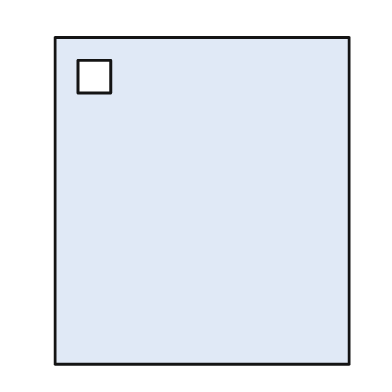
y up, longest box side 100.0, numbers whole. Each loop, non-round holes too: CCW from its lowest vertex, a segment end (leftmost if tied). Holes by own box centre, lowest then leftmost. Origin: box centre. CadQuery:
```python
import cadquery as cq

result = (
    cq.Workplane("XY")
    .moveTo(-45.0, -50.0)
    .lineTo(45.0, -50.0)
    .lineTo(45.0, 50.0)
    .lineTo(-45.0, 50.0)
    .close()
    .moveTo(-38.0, 33.0)
    .lineTo(-28.0, 33.0)
    .lineTo(-28.0, 43.0)
    .lineTo(-38.0, 43.0)
    .close()
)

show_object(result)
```